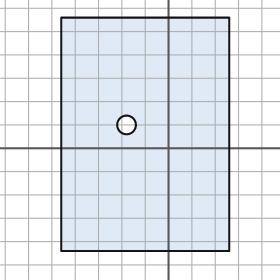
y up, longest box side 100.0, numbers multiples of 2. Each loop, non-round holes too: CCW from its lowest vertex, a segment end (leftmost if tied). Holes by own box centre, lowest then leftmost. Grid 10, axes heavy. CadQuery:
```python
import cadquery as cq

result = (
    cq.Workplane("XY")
    .moveTo(-46.0, -44.0)
    .lineTo(26.0, -44.0)
    .lineTo(26.0, 56.0)
    .lineTo(-46.0, 56.0)
    .close()
    .moveTo(-18.0, 10.0)
    .circle(4.0)
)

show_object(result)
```